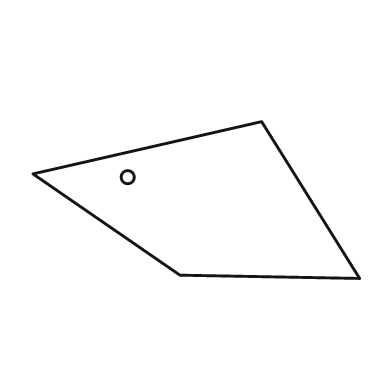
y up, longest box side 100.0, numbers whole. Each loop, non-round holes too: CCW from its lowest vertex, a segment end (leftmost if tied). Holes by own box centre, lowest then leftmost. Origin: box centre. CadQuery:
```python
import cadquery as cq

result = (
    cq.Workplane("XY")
    .moveTo(50.0, -24.0)
    .lineTo(20.0, 24.0)
    .lineTo(-50.0, 8.0)
    .lineTo(-5.0, -23.0)
    .close()
    .moveTo(-21.0, 7.0)
    .circle(2.0)
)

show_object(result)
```